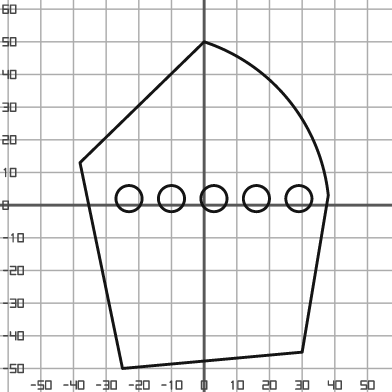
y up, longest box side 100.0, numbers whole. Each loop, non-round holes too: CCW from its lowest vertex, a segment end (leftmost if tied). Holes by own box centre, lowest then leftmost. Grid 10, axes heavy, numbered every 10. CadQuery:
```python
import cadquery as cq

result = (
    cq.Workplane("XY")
    .moveTo(-25.0, -50.0)
    .lineTo(30.0, -45.0)
    .lineTo(38.0, 3.0)
    .threePointArc((26.0, 32.0), (0.0, 50.0))
    .lineTo(-38.0, 13.0)
    .close()
    .moveTo(-23.0, 2.0)
    .circle(4.0)
    .moveTo(-10.0, 2.0)
    .circle(4.0)
    .moveTo(3.0, 2.0)
    .circle(4.0)
    .moveTo(16.0, 2.0)
    .circle(4.0)
    .moveTo(29.0, 2.0)
    .circle(4.0)
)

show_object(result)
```